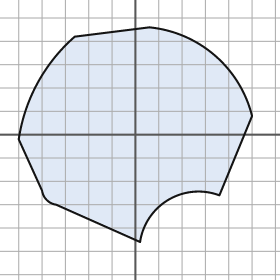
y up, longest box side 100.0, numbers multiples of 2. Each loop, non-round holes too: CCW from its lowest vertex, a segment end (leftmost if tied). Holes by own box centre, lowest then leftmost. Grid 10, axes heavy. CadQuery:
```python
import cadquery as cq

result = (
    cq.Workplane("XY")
    .moveTo(2.0, -46.0)
    .threePointArc((14.0, -28.0), (36.0, -26.0))
    .lineTo(50.0, 8.0)
    .threePointArc((34.0, 34.0), (6.0, 46.0))
    .lineTo(-26.0, 42.0)
    .threePointArc((-42.0, 22.0), (-50.0, -2.0))
    .lineTo(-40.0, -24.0)
    .threePointArc((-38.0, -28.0), (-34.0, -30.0))
    .close()
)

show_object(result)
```